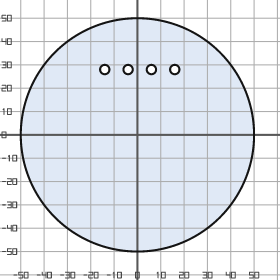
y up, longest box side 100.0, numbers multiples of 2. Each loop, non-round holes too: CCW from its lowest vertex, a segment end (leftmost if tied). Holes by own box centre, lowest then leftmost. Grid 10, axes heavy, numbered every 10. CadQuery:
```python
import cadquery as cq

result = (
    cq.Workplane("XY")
    .moveTo(0.0, 0.0)
    .circle(50.0)
    .moveTo(-14.0, 28.0)
    .circle(2.0)
    .moveTo(-4.0, 28.0)
    .circle(2.0)
    .moveTo(6.0, 28.0)
    .circle(2.0)
    .moveTo(16.0, 28.0)
    .circle(2.0)
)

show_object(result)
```